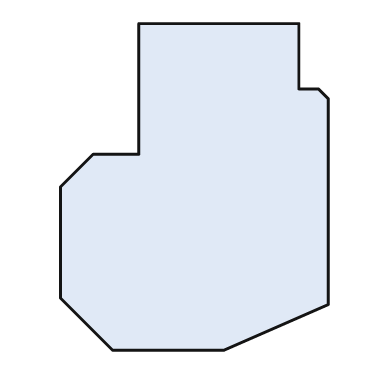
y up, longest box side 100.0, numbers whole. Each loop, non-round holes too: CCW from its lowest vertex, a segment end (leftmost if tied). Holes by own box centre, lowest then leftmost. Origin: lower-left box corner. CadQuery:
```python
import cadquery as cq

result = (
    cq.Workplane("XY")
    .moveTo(16.0, 0.0)
    .lineTo(50.0, 0.0)
    .lineTo(82.0, 14.0)
    .lineTo(82.0, 77.0)
    .lineTo(79.0, 80.0)
    .lineTo(73.0, 80.0)
    .lineTo(73.0, 100.0)
    .lineTo(24.0, 100.0)
    .lineTo(24.0, 60.0)
    .lineTo(10.0, 60.0)
    .lineTo(0.0, 50.0)
    .lineTo(0.0, 16.0)
    .close()
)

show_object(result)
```